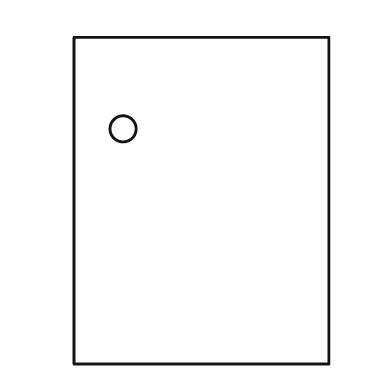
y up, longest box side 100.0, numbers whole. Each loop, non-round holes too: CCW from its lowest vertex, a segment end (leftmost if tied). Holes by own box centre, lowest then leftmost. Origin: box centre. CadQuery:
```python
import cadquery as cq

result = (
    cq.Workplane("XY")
    .moveTo(-39.0, -50.0)
    .lineTo(39.0, -50.0)
    .lineTo(39.0, 50.0)
    .lineTo(-39.0, 50.0)
    .close()
    .moveTo(-24.0, 22.0)
    .circle(4.0)
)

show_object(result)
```